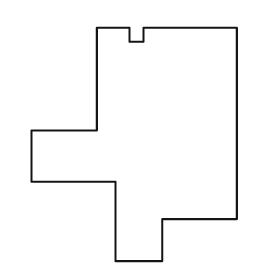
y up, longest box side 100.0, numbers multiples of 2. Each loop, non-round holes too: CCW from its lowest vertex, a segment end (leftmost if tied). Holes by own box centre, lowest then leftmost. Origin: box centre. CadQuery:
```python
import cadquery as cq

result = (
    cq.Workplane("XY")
    .moveTo(-8.0, -50.0)
    .lineTo(12.0, -50.0)
    .lineTo(12.0, -32.0)
    .lineTo(44.0, -32.0)
    .lineTo(44.0, 50.0)
    .lineTo(4.0, 50.0)
    .lineTo(4.0, 44.0)
    .lineTo(-2.0, 44.0)
    .lineTo(-2.0, 50.0)
    .lineTo(-16.0, 50.0)
    .lineTo(-16.0, 6.0)
    .lineTo(-44.0, 6.0)
    .lineTo(-44.0, -16.0)
    .lineTo(-8.0, -16.0)
    .close()
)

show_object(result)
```